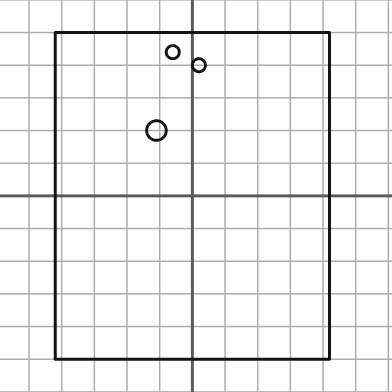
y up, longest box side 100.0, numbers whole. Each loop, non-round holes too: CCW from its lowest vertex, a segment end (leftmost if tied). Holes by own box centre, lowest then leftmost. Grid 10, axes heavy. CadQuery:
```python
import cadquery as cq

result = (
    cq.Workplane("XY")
    .moveTo(-42.0, -50.0)
    .lineTo(42.0, -50.0)
    .lineTo(42.0, 50.0)
    .lineTo(-42.0, 50.0)
    .close()
    .moveTo(-11.0, 20.0)
    .circle(3.0)
    .moveTo(2.0, 40.0)
    .circle(2.0)
    .moveTo(-6.0, 44.0)
    .circle(2.0)
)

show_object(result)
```